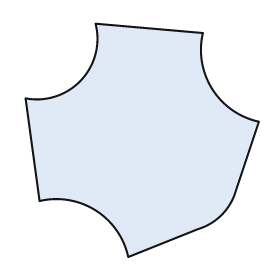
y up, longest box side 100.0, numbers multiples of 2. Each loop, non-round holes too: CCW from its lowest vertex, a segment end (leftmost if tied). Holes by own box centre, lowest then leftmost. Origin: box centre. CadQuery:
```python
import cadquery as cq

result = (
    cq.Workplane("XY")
    .moveTo(-6.0, -50.0)
    .lineTo(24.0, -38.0)
    .threePointArc((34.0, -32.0), (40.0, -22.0))
    .lineTo(50.0, 8.0)
    .threePointArc((30.0, 22.0), (26.0, 46.0))
    .lineTo(-20.0, 50.0)
    .threePointArc((-26.0, 26.0), (-50.0, 18.0))
    .lineTo(-44.0, -26.0)
    .threePointArc((-20.0, -30.0), (-6.0, -50.0))
    .close()
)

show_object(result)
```